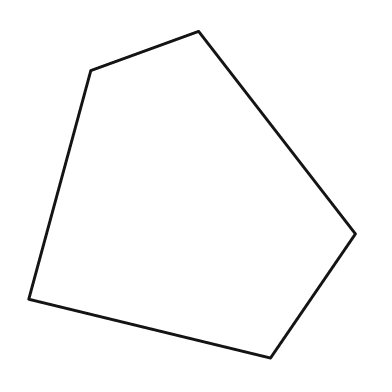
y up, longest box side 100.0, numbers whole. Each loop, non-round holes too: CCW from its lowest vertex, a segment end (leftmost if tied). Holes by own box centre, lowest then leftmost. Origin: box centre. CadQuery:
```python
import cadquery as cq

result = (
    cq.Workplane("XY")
    .moveTo(24.0, -50.0)
    .lineTo(50.0, -12.0)
    .lineTo(2.0, 50.0)
    .lineTo(-31.0, 38.0)
    .lineTo(-50.0, -32.0)
    .close()
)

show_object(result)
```